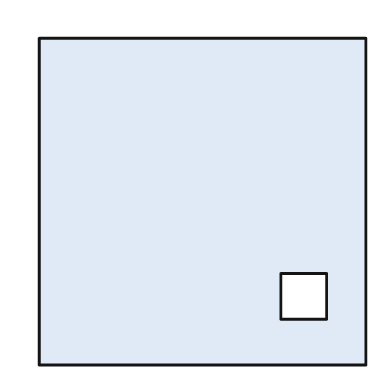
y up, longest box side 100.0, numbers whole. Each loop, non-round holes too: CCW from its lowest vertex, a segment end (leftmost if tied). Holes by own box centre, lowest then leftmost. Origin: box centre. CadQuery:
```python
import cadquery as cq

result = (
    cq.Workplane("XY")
    .moveTo(-50.0, -50.0)
    .lineTo(50.0, -50.0)
    .lineTo(50.0, 50.0)
    .lineTo(-50.0, 50.0)
    .close()
    .moveTo(24.0, -36.0)
    .lineTo(38.0, -36.0)
    .lineTo(38.0, -22.0)
    .lineTo(24.0, -22.0)
    .close()
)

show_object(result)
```